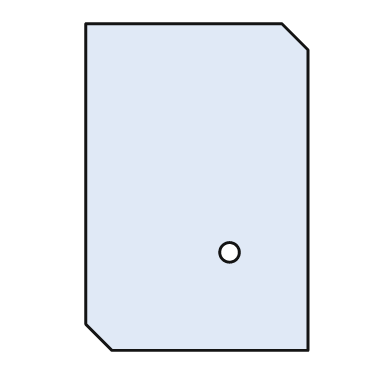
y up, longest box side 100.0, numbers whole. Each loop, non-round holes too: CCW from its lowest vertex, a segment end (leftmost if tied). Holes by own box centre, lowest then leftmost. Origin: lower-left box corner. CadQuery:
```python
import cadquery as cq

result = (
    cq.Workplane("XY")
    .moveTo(8.0, 0.0)
    .lineTo(68.0, 0.0)
    .lineTo(68.0, 92.0)
    .lineTo(60.0, 100.0)
    .lineTo(0.0, 100.0)
    .lineTo(0.0, 8.0)
    .close()
    .moveTo(44.0, 30.0)
    .circle(3.0)
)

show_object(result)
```